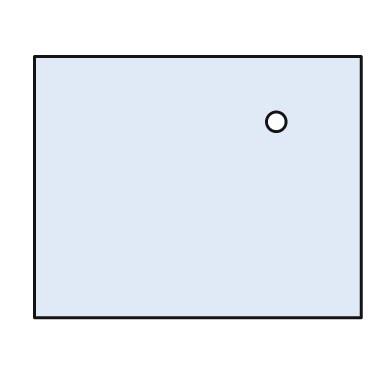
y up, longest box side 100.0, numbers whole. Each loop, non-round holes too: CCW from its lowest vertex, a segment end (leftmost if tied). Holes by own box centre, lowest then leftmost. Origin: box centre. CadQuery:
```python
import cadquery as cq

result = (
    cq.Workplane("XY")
    .moveTo(-50.0, -40.0)
    .lineTo(50.0, -40.0)
    .lineTo(50.0, 40.0)
    .lineTo(-50.0, 40.0)
    .close()
    .moveTo(24.0, 20.0)
    .circle(3.0)
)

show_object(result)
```